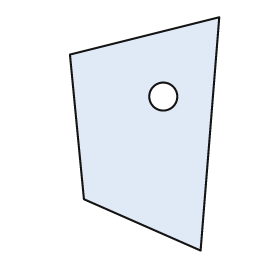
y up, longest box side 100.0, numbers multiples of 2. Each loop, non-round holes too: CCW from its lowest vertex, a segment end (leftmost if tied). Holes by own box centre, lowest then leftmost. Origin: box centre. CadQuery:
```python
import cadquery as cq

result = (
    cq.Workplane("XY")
    .moveTo(24.0, -50.0)
    .lineTo(32.0, 50.0)
    .lineTo(-32.0, 34.0)
    .lineTo(-26.0, -28.0)
    .close()
    .moveTo(8.0, 16.0)
    .circle(6.0)
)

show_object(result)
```